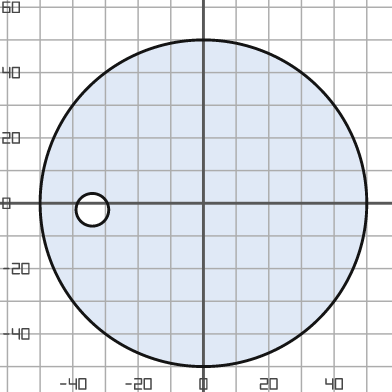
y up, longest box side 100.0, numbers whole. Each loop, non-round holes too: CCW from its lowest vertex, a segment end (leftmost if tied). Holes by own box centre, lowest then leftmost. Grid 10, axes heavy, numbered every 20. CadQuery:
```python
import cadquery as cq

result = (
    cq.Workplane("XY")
    .moveTo(0.0, 0.0)
    .circle(50.0)
    .moveTo(-34.0, -2.0)
    .circle(5.0)
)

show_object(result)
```